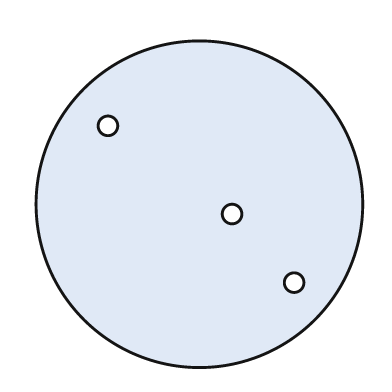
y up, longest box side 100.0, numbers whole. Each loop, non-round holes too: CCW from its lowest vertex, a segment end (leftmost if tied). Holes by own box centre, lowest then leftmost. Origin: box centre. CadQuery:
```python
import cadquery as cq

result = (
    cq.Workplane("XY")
    .moveTo(0.0, 0.0)
    .circle(50.0)
    .moveTo(29.0, -24.0)
    .circle(3.0)
    .moveTo(10.0, -3.0)
    .circle(3.0)
    .moveTo(-28.0, 24.0)
    .circle(3.0)
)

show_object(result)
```